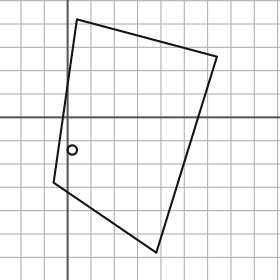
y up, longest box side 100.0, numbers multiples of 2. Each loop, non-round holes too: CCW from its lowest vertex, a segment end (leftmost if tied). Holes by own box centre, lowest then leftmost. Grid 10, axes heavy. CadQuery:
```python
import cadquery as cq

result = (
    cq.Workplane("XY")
    .moveTo(38.0, -58.0)
    .lineTo(64.0, 26.0)
    .lineTo(4.0, 42.0)
    .lineTo(-6.0, -28.0)
    .close()
    .moveTo(2.0, -14.0)
    .circle(2.0)
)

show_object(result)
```